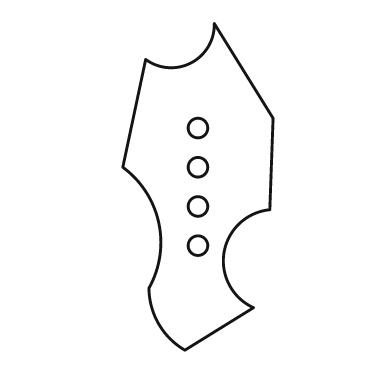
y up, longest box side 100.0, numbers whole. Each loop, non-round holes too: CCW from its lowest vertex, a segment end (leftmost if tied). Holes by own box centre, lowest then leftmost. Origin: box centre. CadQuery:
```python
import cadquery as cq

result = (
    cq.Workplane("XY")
    .moveTo(-4.0, -50.0)
    .lineTo(17.0, -37.0)
    .threePointArc((8.0, -20.0), (22.0, -7.0))
    .lineTo(23.0, 21.0)
    .lineTo(5.0, 50.0)
    .threePointArc((-2.0, 38.0), (-16.0, 39.0))
    .lineTo(-23.0, 6.0)
    .threePointArc((-12.0, -11.0), (-15.0, -31.0))
    .threePointArc((-12.0, -42.0), (-4.0, -50.0))
    .close()
    .moveTo(0.0, -18.0)
    .circle(3.0)
    .moveTo(0.0, -6.0)
    .circle(3.0)
    .moveTo(0.0, 6.0)
    .circle(3.0)
    .moveTo(0.0, 18.0)
    .circle(3.0)
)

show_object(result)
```